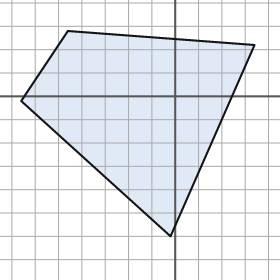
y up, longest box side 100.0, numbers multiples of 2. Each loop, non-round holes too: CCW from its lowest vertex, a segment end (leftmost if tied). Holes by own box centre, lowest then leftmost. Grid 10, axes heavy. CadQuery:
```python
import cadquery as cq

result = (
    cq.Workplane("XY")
    .moveTo(-2.0, -60.0)
    .lineTo(34.0, 22.0)
    .lineTo(-46.0, 28.0)
    .lineTo(-66.0, -2.0)
    .close()
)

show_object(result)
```